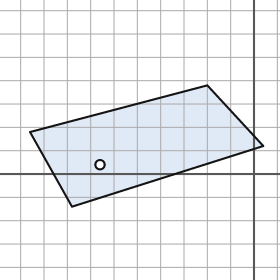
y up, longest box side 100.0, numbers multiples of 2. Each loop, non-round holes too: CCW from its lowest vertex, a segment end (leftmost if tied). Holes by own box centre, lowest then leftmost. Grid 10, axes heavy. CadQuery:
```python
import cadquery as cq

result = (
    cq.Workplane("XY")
    .moveTo(-78.0, -14.0)
    .lineTo(4.0, 12.0)
    .lineTo(-20.0, 38.0)
    .lineTo(-96.0, 18.0)
    .close()
    .moveTo(-66.0, 4.0)
    .circle(2.0)
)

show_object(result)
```